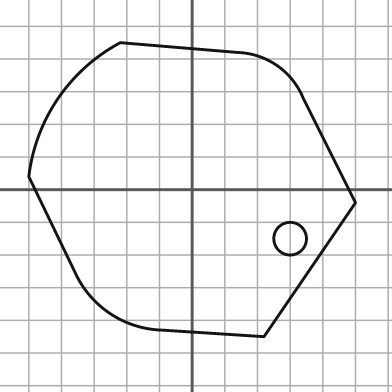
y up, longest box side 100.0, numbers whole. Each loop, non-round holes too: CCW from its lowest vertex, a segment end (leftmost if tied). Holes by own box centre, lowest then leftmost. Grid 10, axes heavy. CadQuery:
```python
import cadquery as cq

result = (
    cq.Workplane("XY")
    .moveTo(22.0, -45.0)
    .lineTo(50.0, -4.0)
    .lineTo(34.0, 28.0)
    .threePointArc((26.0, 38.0), (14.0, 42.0))
    .lineTo(-22.0, 45.0)
    .threePointArc((-41.0, 28.0), (-50.0, 4.0))
    .lineTo(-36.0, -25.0)
    .threePointArc((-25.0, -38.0), (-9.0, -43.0))
    .close()
    .moveTo(30.0, -15.0)
    .circle(5.0)
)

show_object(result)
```